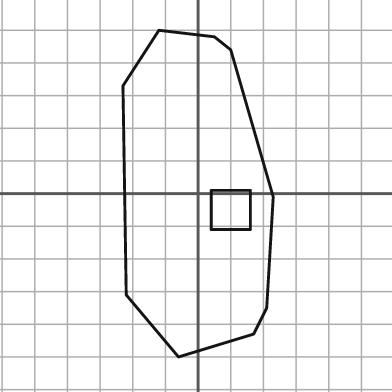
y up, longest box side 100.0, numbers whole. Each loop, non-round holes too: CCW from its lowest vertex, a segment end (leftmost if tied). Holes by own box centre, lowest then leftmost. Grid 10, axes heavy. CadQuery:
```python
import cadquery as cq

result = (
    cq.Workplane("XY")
    .moveTo(-6.0, -50.0)
    .lineTo(17.0, -43.0)
    .lineTo(21.0, -35.0)
    .lineTo(23.0, -1.0)
    .lineTo(10.0, 44.0)
    .lineTo(5.0, 48.0)
    .lineTo(-12.0, 50.0)
    .lineTo(-23.0, 33.0)
    .lineTo(-22.0, -31.0)
    .close()
    .moveTo(4.0, -11.0)
    .lineTo(16.0, -11.0)
    .lineTo(16.0, 1.0)
    .lineTo(4.0, 1.0)
    .close()
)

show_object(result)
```